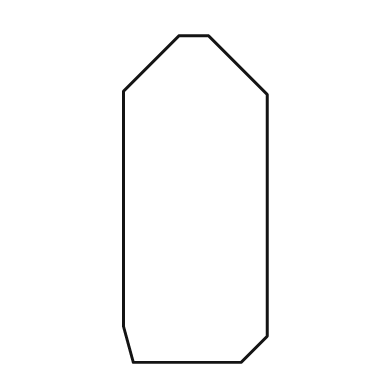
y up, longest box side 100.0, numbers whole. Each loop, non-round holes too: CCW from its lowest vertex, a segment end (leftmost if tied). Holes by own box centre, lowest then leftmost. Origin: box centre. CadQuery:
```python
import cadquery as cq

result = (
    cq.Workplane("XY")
    .moveTo(-19.0, -50.0)
    .lineTo(14.0, -50.0)
    .lineTo(22.0, -42.0)
    .lineTo(22.0, 32.0)
    .lineTo(4.0, 50.0)
    .lineTo(-5.0, 50.0)
    .lineTo(-22.0, 33.0)
    .lineTo(-22.0, -39.0)
    .close()
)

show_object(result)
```